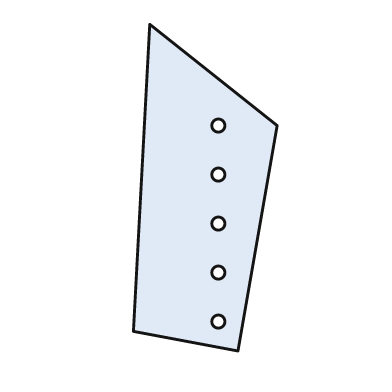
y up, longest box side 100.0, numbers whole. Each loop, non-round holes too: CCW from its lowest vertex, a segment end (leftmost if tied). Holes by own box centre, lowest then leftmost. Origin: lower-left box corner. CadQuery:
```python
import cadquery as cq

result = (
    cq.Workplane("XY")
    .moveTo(32.0, 0.0)
    .lineTo(44.0, 69.0)
    .lineTo(5.0, 100.0)
    .lineTo(0.0, 6.0)
    .close()
    .moveTo(26.0, 9.0)
    .circle(2.0)
    .moveTo(26.0, 24.0)
    .circle(2.0)
    .moveTo(26.0, 39.0)
    .circle(2.0)
    .moveTo(26.0, 54.0)
    .circle(2.0)
    .moveTo(26.0, 69.0)
    .circle(2.0)
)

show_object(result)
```